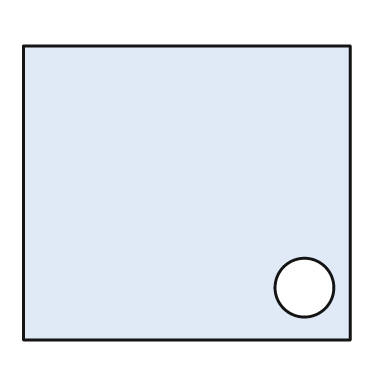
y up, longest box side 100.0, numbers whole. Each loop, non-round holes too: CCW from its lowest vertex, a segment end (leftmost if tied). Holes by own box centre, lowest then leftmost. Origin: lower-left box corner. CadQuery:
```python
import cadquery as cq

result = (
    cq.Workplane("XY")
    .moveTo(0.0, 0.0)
    .lineTo(100.0, 0.0)
    .lineTo(100.0, 90.0)
    .lineTo(0.0, 90.0)
    .close()
    .moveTo(86.0, 16.0)
    .circle(9.0)
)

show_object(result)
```